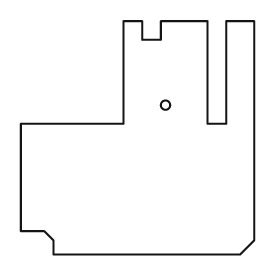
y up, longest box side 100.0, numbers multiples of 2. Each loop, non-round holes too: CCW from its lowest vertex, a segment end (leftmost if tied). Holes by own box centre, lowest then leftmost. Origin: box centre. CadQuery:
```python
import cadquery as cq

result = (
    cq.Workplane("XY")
    .moveTo(-36.0, -50.0)
    .lineTo(44.0, -50.0)
    .lineTo(50.0, -44.0)
    .lineTo(50.0, 50.0)
    .lineTo(38.0, 50.0)
    .lineTo(38.0, 6.0)
    .lineTo(30.0, 6.0)
    .lineTo(30.0, 50.0)
    .lineTo(10.0, 50.0)
    .lineTo(10.0, 42.0)
    .lineTo(2.0, 42.0)
    .lineTo(2.0, 50.0)
    .lineTo(-6.0, 50.0)
    .lineTo(-6.0, 6.0)
    .lineTo(-50.0, 6.0)
    .lineTo(-50.0, -40.0)
    .lineTo(-40.0, -40.0)
    .lineTo(-36.0, -44.0)
    .close()
    .moveTo(12.0, 14.0)
    .circle(2.0)
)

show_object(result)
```